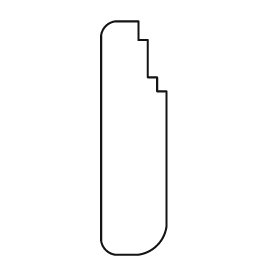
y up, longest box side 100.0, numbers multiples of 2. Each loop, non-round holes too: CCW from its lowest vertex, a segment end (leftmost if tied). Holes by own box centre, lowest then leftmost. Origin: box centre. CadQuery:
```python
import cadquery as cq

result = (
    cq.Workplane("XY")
    .moveTo(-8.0, -50.0)
    .lineTo(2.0, -50.0)
    .threePointArc((10.0, -46.0), (14.0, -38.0))
    .lineTo(14.0, 20.0)
    .lineTo(10.0, 20.0)
    .lineTo(10.0, 26.0)
    .lineTo(6.0, 26.0)
    .lineTo(6.0, 42.0)
    .lineTo(2.0, 42.0)
    .lineTo(2.0, 50.0)
    .lineTo(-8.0, 50.0)
    .threePointArc((-12.0, 48.0), (-14.0, 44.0))
    .lineTo(-14.0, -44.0)
    .threePointArc((-12.0, -48.0), (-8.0, -50.0))
    .close()
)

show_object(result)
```